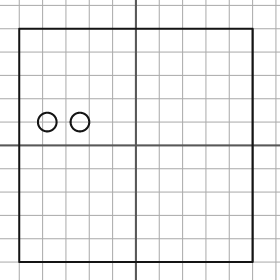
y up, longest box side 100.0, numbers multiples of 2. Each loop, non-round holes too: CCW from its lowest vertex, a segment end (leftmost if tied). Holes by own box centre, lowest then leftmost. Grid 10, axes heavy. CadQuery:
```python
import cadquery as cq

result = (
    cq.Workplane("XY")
    .moveTo(-50.0, -50.0)
    .lineTo(50.0, -50.0)
    .lineTo(50.0, 50.0)
    .lineTo(-50.0, 50.0)
    .close()
    .moveTo(-38.0, 10.0)
    .circle(4.0)
    .moveTo(-24.0, 10.0)
    .circle(4.0)
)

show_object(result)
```